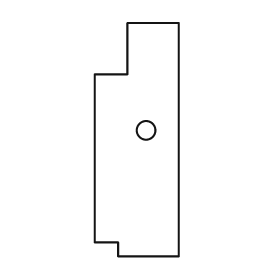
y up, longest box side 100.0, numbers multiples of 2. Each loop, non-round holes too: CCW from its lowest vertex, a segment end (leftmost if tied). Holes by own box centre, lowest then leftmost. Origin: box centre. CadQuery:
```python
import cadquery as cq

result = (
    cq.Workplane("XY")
    .moveTo(-8.0, -50.0)
    .lineTo(18.0, -50.0)
    .lineTo(18.0, 50.0)
    .lineTo(-4.0, 50.0)
    .lineTo(-4.0, 28.0)
    .lineTo(-18.0, 28.0)
    .lineTo(-18.0, -44.0)
    .lineTo(-8.0, -44.0)
    .close()
    .moveTo(4.0, 4.0)
    .circle(4.0)
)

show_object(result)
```